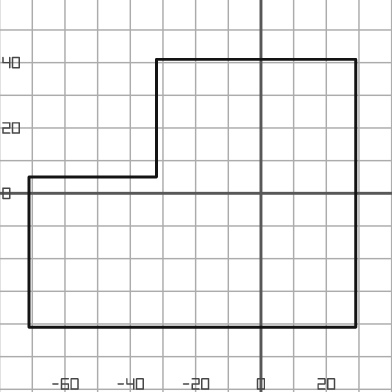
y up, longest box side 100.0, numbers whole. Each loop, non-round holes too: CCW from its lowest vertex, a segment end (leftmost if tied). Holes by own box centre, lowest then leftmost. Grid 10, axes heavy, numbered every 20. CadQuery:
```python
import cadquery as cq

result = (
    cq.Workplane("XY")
    .moveTo(-71.0, -41.0)
    .lineTo(29.0, -41.0)
    .lineTo(29.0, 41.0)
    .lineTo(-32.0, 41.0)
    .lineTo(-32.0, 5.0)
    .lineTo(-71.0, 5.0)
    .close()
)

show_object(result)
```